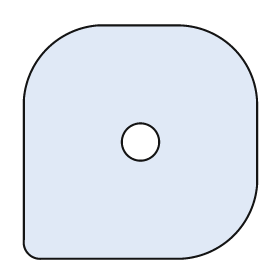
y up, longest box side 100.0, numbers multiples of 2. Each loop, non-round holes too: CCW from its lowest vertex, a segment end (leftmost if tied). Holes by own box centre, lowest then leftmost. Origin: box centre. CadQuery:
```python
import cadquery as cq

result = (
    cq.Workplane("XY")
    .moveTo(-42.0, -50.0)
    .lineTo(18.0, -50.0)
    .threePointArc((40.0, -40.0), (50.0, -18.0))
    .lineTo(50.0, 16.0)
    .threePointArc((40.0, 40.0), (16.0, 50.0))
    .lineTo(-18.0, 50.0)
    .threePointArc((-40.0, 40.0), (-50.0, 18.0))
    .lineTo(-50.0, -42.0)
    .threePointArc((-48.0, -48.0), (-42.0, -50.0))
    .close()
    .moveTo(0.0, 0.0)
    .circle(8.0)
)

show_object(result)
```